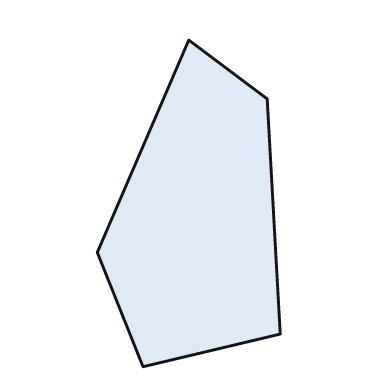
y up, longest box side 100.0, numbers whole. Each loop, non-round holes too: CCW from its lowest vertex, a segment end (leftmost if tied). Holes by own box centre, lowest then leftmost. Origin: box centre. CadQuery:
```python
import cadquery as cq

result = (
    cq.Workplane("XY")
    .moveTo(-14.0, -50.0)
    .lineTo(28.0, -40.0)
    .lineTo(24.0, 32.0)
    .lineTo(0.0, 50.0)
    .lineTo(-28.0, -15.0)
    .close()
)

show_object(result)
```